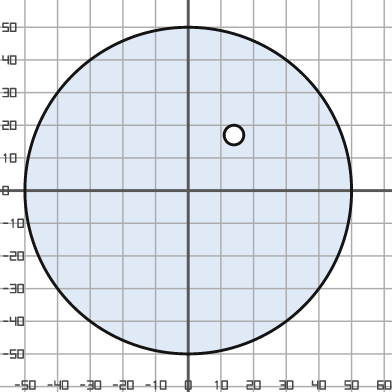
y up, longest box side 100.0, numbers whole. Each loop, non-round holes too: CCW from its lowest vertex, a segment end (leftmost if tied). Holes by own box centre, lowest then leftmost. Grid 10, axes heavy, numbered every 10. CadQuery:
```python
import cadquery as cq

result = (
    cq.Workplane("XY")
    .moveTo(0.0, 0.0)
    .circle(50.0)
    .moveTo(14.0, 17.0)
    .circle(3.0)
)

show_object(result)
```